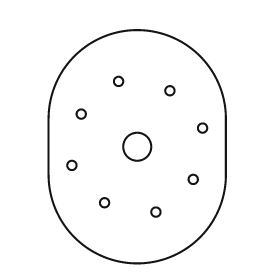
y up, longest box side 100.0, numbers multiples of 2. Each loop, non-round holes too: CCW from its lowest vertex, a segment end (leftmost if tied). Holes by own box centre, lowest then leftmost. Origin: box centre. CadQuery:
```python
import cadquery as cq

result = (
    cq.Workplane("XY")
    .moveTo(-38.0, -12.0)
    .threePointArc((0.0, -50.0), (38.0, -12.0))
    .lineTo(38.0, 12.0)
    .threePointArc((0.0, 50.0), (-38.0, 12.0))
    .close()
    .moveTo(8.0, -28.0)
    .circle(2.0)
    .moveTo(-14.0, -24.0)
    .circle(2.0)
    .moveTo(24.0, -14.0)
    .circle(2.0)
    .moveTo(-28.0, -8.0)
    .circle(2.0)
    .moveTo(0.0, 0.0)
    .circle(6.0)
    .moveTo(28.0, 8.0)
    .circle(2.0)
    .moveTo(-24.0, 14.0)
    .circle(2.0)
    .moveTo(14.0, 24.0)
    .circle(2.0)
    .moveTo(-8.0, 28.0)
    .circle(2.0)
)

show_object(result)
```